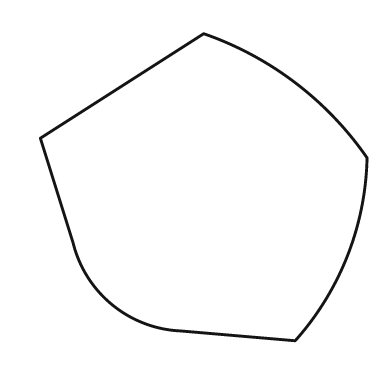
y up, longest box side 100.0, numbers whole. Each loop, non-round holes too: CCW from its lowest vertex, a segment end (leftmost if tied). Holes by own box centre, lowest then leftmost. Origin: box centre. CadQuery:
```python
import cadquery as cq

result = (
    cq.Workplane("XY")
    .moveTo(28.0, -47.0)
    .threePointArc((44.0, -21.0), (50.0, 9.0))
    .threePointArc((28.0, 32.0), (0.0, 47.0))
    .lineTo(-50.0, 15.0)
    .lineTo(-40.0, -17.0)
    .threePointArc((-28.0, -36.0), (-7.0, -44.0))
    .close()
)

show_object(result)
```